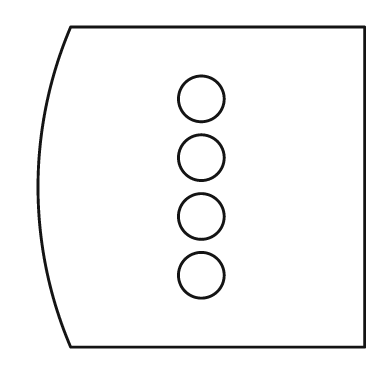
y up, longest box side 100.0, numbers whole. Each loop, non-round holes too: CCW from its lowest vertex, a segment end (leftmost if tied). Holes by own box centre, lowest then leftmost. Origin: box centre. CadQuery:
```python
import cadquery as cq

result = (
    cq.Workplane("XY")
    .moveTo(-40.0, -49.0)
    .lineTo(50.0, -49.0)
    .lineTo(50.0, 49.0)
    .lineTo(-40.0, 49.0)
    .threePointArc((-50.0, 0.0), (-40.0, -49.0))
    .close()
    .moveTo(0.0, -27.0)
    .circle(7.0)
    .moveTo(0.0, -9.0)
    .circle(7.0)
    .moveTo(0.0, 9.0)
    .circle(7.0)
    .moveTo(0.0, 27.0)
    .circle(7.0)
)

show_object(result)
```